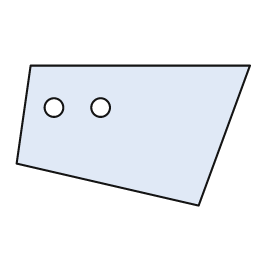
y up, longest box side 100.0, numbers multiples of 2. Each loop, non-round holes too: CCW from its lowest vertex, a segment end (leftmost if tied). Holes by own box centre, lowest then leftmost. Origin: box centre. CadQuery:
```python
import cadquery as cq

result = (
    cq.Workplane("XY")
    .moveTo(28.0, -30.0)
    .lineTo(50.0, 30.0)
    .lineTo(-44.0, 30.0)
    .lineTo(-50.0, -12.0)
    .close()
    .moveTo(-34.0, 12.0)
    .circle(4.0)
    .moveTo(-14.0, 12.0)
    .circle(4.0)
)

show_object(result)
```